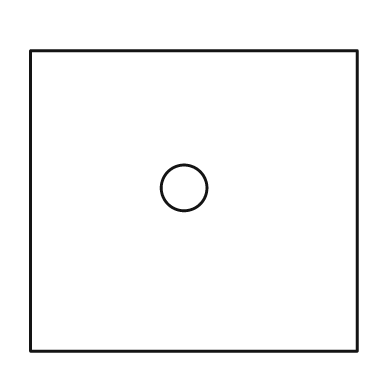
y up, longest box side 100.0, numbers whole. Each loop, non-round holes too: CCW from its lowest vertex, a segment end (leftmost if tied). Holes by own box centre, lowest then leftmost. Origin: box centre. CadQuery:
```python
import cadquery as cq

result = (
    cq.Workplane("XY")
    .moveTo(-50.0, -46.0)
    .lineTo(50.0, -46.0)
    .lineTo(50.0, 46.0)
    .lineTo(-50.0, 46.0)
    .close()
    .moveTo(-3.0, 4.0)
    .circle(7.0)
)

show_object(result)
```